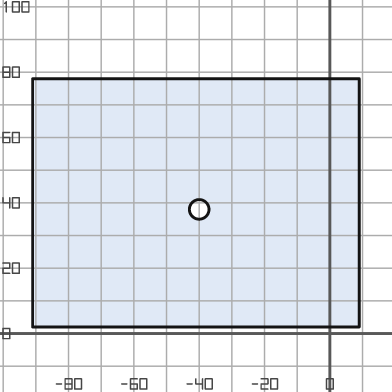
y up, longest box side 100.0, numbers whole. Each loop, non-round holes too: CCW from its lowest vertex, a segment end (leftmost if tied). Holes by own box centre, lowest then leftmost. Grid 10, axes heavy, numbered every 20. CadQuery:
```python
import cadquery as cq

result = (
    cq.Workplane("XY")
    .moveTo(-91.0, 2.0)
    .lineTo(9.0, 2.0)
    .lineTo(9.0, 78.0)
    .lineTo(-91.0, 78.0)
    .close()
    .moveTo(-40.0, 38.0)
    .circle(3.0)
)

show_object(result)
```